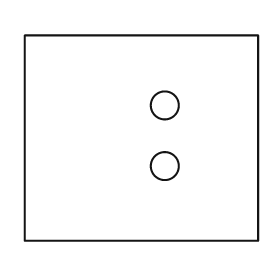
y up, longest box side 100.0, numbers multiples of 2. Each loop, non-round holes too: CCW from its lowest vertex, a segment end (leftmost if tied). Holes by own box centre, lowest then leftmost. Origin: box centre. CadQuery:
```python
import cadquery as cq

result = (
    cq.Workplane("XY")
    .moveTo(-50.0, -44.0)
    .lineTo(50.0, -44.0)
    .lineTo(50.0, 44.0)
    .lineTo(-50.0, 44.0)
    .close()
    .moveTo(10.0, -12.0)
    .circle(6.0)
    .moveTo(10.0, 14.0)
    .circle(6.0)
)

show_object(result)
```